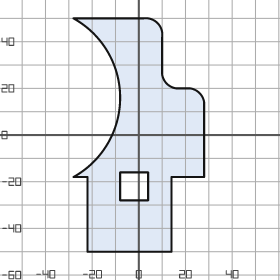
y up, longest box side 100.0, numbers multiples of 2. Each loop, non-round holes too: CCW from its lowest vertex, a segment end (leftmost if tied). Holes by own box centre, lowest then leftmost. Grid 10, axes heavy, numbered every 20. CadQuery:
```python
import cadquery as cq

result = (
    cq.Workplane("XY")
    .moveTo(-22.0, -50.0)
    .lineTo(14.0, -50.0)
    .lineTo(14.0, -18.0)
    .lineTo(28.0, -18.0)
    .lineTo(28.0, 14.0)
    .threePointArc((26.0, 18.0), (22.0, 20.0))
    .lineTo(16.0, 20.0)
    .threePointArc((12.0, 22.0), (10.0, 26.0))
    .lineTo(10.0, 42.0)
    .threePointArc((8.0, 48.0), (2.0, 50.0))
    .lineTo(-28.0, 50.0)
    .threePointArc((-8.0, 16.0), (-28.0, -18.0))
    .lineTo(-22.0, -18.0)
    .close()
    .moveTo(-8.0, -28.0)
    .lineTo(4.0, -28.0)
    .lineTo(4.0, -16.0)
    .lineTo(-8.0, -16.0)
    .close()
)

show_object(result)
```